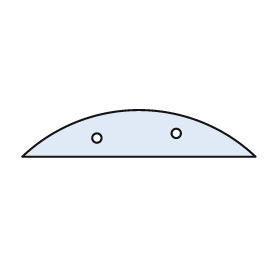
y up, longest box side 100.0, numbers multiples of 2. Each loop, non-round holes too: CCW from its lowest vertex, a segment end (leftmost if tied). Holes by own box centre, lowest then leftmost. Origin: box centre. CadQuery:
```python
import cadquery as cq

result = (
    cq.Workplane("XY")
    .moveTo(-50.0, -10.0)
    .lineTo(50.0, -10.0)
    .threePointArc((0.0, 10.0), (-50.0, -10.0))
    .close()
    .moveTo(-18.0, -2.0)
    .circle(2.0)
    .moveTo(16.0, 0.0)
    .circle(2.0)
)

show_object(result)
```